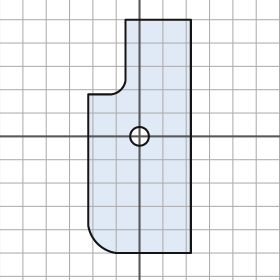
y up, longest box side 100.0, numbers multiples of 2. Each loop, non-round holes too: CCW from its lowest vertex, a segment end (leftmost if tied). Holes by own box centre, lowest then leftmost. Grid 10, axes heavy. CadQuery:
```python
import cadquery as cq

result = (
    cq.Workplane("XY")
    .moveTo(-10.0, -50.0)
    .lineTo(22.0, -50.0)
    .lineTo(22.0, 50.0)
    .lineTo(-6.0, 50.0)
    .lineTo(-6.0, 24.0)
    .threePointArc((-8.0, 20.0), (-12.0, 18.0))
    .lineTo(-22.0, 18.0)
    .lineTo(-22.0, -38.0)
    .threePointArc((-18.0, -46.0), (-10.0, -50.0))
    .close()
    .moveTo(0.0, 0.0)
    .circle(4.0)
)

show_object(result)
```